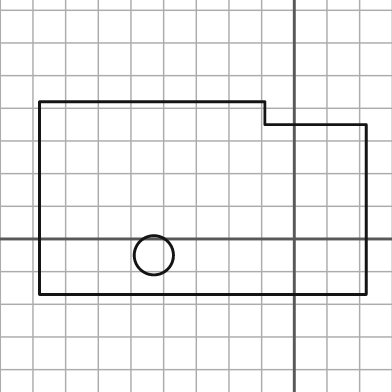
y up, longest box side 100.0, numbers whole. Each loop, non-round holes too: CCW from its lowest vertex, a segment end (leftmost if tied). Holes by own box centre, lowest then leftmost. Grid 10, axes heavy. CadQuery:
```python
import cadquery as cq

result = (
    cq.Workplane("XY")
    .moveTo(-78.0, -17.0)
    .lineTo(22.0, -17.0)
    .lineTo(22.0, 35.0)
    .lineTo(-9.0, 35.0)
    .lineTo(-9.0, 42.0)
    .lineTo(-78.0, 42.0)
    .close()
    .moveTo(-43.0, -5.0)
    .circle(6.0)
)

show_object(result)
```